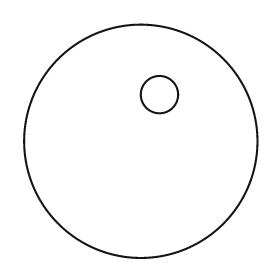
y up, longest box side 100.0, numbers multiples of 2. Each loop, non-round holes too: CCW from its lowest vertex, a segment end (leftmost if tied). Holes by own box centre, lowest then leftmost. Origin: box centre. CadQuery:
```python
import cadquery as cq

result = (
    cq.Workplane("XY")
    .moveTo(0.0, 0.0)
    .circle(50.0)
    .moveTo(8.0, 20.0)
    .circle(8.0)
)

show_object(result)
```